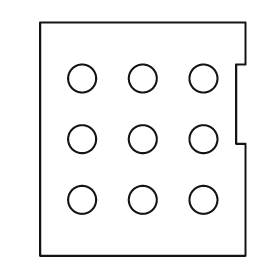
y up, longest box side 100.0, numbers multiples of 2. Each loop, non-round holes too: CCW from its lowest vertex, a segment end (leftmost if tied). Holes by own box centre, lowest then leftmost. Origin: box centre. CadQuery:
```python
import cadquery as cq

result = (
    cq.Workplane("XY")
    .moveTo(-44.0, -50.0)
    .lineTo(44.0, -50.0)
    .lineTo(44.0, -2.0)
    .lineTo(40.0, -2.0)
    .lineTo(40.0, 32.0)
    .lineTo(44.0, 32.0)
    .lineTo(44.0, 50.0)
    .lineTo(-44.0, 50.0)
    .close()
    .moveTo(-26.0, -26.0)
    .circle(6.0)
    .moveTo(0.0, -26.0)
    .circle(6.0)
    .moveTo(26.0, -26.0)
    .circle(6.0)
    .moveTo(-26.0, 0.0)
    .circle(6.0)
    .moveTo(0.0, 0.0)
    .circle(6.0)
    .moveTo(26.0, 0.0)
    .circle(6.0)
    .moveTo(-26.0, 26.0)
    .circle(6.0)
    .moveTo(0.0, 26.0)
    .circle(6.0)
    .moveTo(26.0, 26.0)
    .circle(6.0)
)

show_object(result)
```